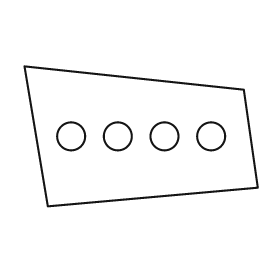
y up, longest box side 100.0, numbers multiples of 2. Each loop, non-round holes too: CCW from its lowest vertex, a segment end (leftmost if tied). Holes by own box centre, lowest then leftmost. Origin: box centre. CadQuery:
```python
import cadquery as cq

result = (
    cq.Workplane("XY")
    .moveTo(-40.0, -30.0)
    .lineTo(50.0, -22.0)
    .lineTo(44.0, 20.0)
    .lineTo(-50.0, 30.0)
    .close()
    .moveTo(-30.0, 0.0)
    .circle(6.0)
    .moveTo(-10.0, 0.0)
    .circle(6.0)
    .moveTo(10.0, 0.0)
    .circle(6.0)
    .moveTo(30.0, 0.0)
    .circle(6.0)
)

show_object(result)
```